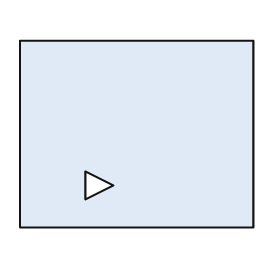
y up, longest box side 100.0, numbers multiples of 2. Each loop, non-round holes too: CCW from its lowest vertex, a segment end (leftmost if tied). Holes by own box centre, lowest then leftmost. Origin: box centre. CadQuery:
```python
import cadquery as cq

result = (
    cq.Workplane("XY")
    .moveTo(-50.0, -40.0)
    .lineTo(50.0, -40.0)
    .lineTo(50.0, 40.0)
    .lineTo(-50.0, 40.0)
    .close()
    .moveTo(-22.0, -28.0)
    .lineTo(-10.0, -22.0)
    .lineTo(-22.0, -16.0)
    .close()
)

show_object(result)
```